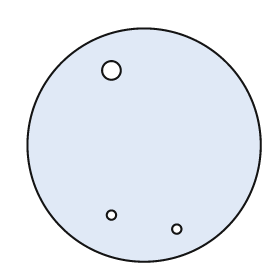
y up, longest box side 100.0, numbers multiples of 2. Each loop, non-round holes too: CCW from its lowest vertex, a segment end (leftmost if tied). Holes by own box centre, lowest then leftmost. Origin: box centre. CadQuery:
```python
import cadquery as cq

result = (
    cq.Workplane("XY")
    .moveTo(0.0, 0.0)
    .circle(50.0)
    .moveTo(14.0, -36.0)
    .circle(2.0)
    .moveTo(-14.0, -30.0)
    .circle(2.0)
    .moveTo(-14.0, 32.0)
    .circle(4.0)
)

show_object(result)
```